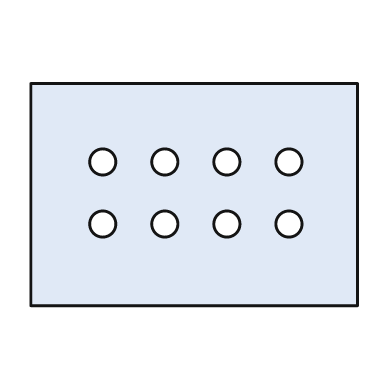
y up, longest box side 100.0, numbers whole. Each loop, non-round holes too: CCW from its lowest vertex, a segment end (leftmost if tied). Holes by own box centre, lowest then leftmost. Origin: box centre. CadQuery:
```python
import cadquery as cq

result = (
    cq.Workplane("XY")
    .moveTo(-50.0, -34.0)
    .lineTo(50.0, -34.0)
    .lineTo(50.0, 34.0)
    .lineTo(-50.0, 34.0)
    .close()
    .moveTo(-28.0, -9.0)
    .circle(4.0)
    .moveTo(-9.0, -9.0)
    .circle(4.0)
    .moveTo(10.0, -9.0)
    .circle(4.0)
    .moveTo(29.0, -9.0)
    .circle(4.0)
    .moveTo(-28.0, 10.0)
    .circle(4.0)
    .moveTo(-9.0, 10.0)
    .circle(4.0)
    .moveTo(10.0, 10.0)
    .circle(4.0)
    .moveTo(29.0, 10.0)
    .circle(4.0)
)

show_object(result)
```